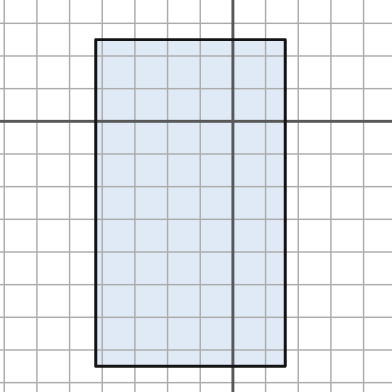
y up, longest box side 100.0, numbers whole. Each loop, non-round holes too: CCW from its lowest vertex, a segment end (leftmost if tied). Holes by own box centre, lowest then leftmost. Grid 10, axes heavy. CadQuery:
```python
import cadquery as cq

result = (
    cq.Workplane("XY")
    .moveTo(-42.0, -75.0)
    .lineTo(16.0, -75.0)
    .lineTo(16.0, 25.0)
    .lineTo(-42.0, 25.0)
    .close()
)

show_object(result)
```